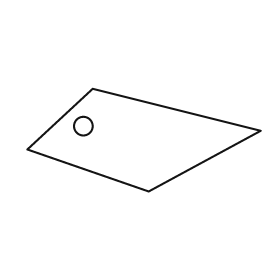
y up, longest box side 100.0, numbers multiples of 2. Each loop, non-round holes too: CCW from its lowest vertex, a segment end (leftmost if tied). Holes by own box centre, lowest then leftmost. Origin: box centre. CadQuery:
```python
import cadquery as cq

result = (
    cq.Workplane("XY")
    .moveTo(2.0, -22.0)
    .lineTo(50.0, 4.0)
    .lineTo(-22.0, 22.0)
    .lineTo(-50.0, -4.0)
    .close()
    .moveTo(-26.0, 6.0)
    .circle(4.0)
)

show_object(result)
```